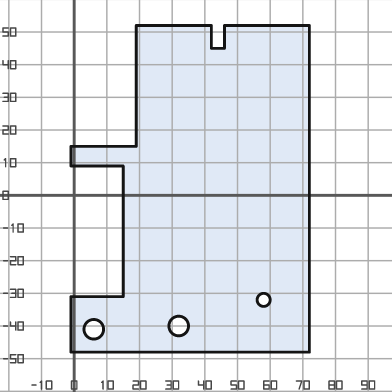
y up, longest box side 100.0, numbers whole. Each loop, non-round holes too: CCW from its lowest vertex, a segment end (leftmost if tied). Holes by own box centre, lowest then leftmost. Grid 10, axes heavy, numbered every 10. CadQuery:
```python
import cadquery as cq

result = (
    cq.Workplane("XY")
    .moveTo(-1.0, -48.0)
    .lineTo(72.0, -48.0)
    .lineTo(72.0, 52.0)
    .lineTo(46.0, 52.0)
    .lineTo(46.0, 45.0)
    .lineTo(42.0, 45.0)
    .lineTo(42.0, 52.0)
    .lineTo(19.0, 52.0)
    .lineTo(19.0, 15.0)
    .lineTo(-1.0, 15.0)
    .lineTo(-1.0, 9.0)
    .lineTo(15.0, 9.0)
    .lineTo(15.0, -31.0)
    .lineTo(-1.0, -31.0)
    .close()
    .moveTo(6.0, -41.0)
    .circle(3.0)
    .moveTo(32.0, -40.0)
    .circle(3.0)
    .moveTo(58.0, -32.0)
    .circle(2.0)
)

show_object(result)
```